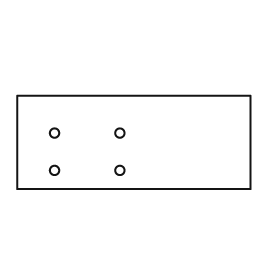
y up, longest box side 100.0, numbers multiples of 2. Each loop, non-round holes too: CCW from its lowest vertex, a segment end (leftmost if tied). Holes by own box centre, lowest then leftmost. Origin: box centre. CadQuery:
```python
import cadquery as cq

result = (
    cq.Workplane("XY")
    .moveTo(-50.0, -20.0)
    .lineTo(50.0, -20.0)
    .lineTo(50.0, 20.0)
    .lineTo(-50.0, 20.0)
    .close()
    .moveTo(-34.0, -12.0)
    .circle(2.0)
    .moveTo(-6.0, -12.0)
    .circle(2.0)
    .moveTo(-34.0, 4.0)
    .circle(2.0)
    .moveTo(-6.0, 4.0)
    .circle(2.0)
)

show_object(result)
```